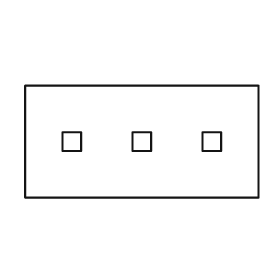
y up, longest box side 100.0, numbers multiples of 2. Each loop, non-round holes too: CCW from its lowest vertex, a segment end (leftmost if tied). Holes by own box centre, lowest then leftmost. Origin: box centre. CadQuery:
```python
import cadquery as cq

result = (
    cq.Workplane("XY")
    .moveTo(-50.0, -24.0)
    .lineTo(50.0, -24.0)
    .lineTo(50.0, 24.0)
    .lineTo(-50.0, 24.0)
    .close()
    .moveTo(-34.0, -4.0)
    .lineTo(-26.0, -4.0)
    .lineTo(-26.0, 4.0)
    .lineTo(-34.0, 4.0)
    .close()
    .moveTo(-4.0, -4.0)
    .lineTo(4.0, -4.0)
    .lineTo(4.0, 4.0)
    .lineTo(-4.0, 4.0)
    .close()
    .moveTo(26.0, -4.0)
    .lineTo(34.0, -4.0)
    .lineTo(34.0, 4.0)
    .lineTo(26.0, 4.0)
    .close()
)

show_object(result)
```